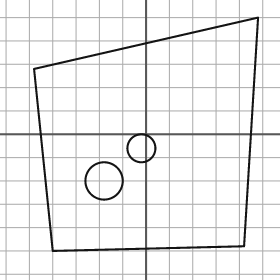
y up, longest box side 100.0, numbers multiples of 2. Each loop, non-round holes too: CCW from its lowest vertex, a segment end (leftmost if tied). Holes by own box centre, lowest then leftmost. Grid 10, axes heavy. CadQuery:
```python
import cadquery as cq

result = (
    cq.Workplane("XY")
    .moveTo(-40.0, -50.0)
    .lineTo(42.0, -48.0)
    .lineTo(48.0, 50.0)
    .lineTo(-48.0, 28.0)
    .close()
    .moveTo(-18.0, -20.0)
    .circle(8.0)
    .moveTo(-2.0, -6.0)
    .circle(6.0)
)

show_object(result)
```